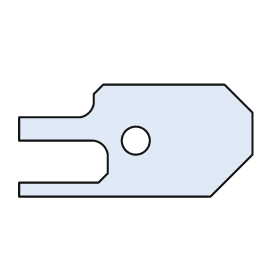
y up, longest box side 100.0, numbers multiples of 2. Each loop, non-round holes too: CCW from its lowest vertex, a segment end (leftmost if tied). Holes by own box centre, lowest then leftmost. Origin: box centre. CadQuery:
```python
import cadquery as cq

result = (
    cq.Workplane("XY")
    .moveTo(-50.0, -24.0)
    .lineTo(32.0, -24.0)
    .lineTo(50.0, -6.0)
    .lineTo(50.0, 12.0)
    .lineTo(38.0, 24.0)
    .lineTo(-14.0, 24.0)
    .lineTo(-18.0, 20.0)
    .lineTo(-18.0, 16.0)
    .threePointArc((-20.0, 12.0), (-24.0, 10.0))
    .lineTo(-50.0, 10.0)
    .lineTo(-50.0, 0.0)
    .lineTo(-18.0, 0.0)
    .threePointArc((-14.0, -2.0), (-12.0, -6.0))
    .lineTo(-12.0, -14.0)
    .lineTo(-16.0, -18.0)
    .lineTo(-50.0, -18.0)
    .close()
    .moveTo(0.0, 0.0)
    .circle(6.0)
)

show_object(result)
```